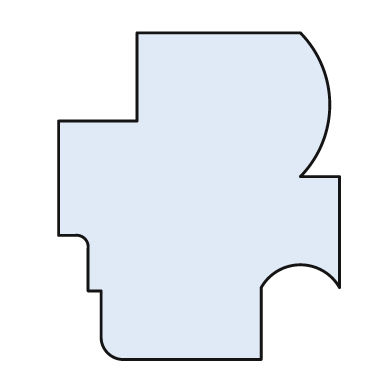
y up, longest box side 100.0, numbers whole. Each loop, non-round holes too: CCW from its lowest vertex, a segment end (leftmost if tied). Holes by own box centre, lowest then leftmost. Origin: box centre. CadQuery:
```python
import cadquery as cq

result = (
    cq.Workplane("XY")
    .moveTo(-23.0, -50.0)
    .lineTo(19.0, -50.0)
    .lineTo(19.0, -28.0)
    .threePointArc((31.0, -21.0), (43.0, -28.0))
    .lineTo(43.0, 6.0)
    .lineTo(31.0, 6.0)
    .threePointArc((40.0, 28.0), (31.0, 50.0))
    .lineTo(-19.0, 50.0)
    .lineTo(-19.0, 23.0)
    .lineTo(-43.0, 23.0)
    .lineTo(-43.0, -12.0)
    .lineTo(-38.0, -12.0)
    .threePointArc((-35.0, -13.0), (-34.0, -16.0))
    .lineTo(-34.0, -29.0)
    .lineTo(-30.0, -29.0)
    .lineTo(-30.0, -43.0)
    .threePointArc((-28.0, -48.0), (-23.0, -50.0))
    .close()
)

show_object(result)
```